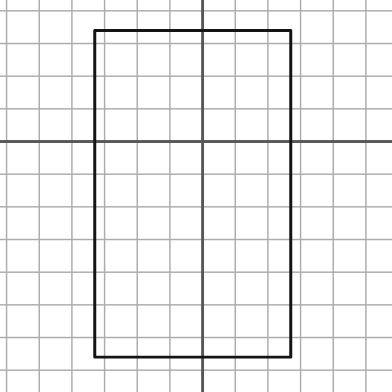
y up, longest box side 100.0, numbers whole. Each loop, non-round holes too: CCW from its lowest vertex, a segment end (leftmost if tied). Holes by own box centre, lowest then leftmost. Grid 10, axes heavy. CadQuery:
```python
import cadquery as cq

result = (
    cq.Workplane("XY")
    .moveTo(-33.0, -66.0)
    .lineTo(27.0, -66.0)
    .lineTo(27.0, 34.0)
    .lineTo(-33.0, 34.0)
    .close()
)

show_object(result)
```